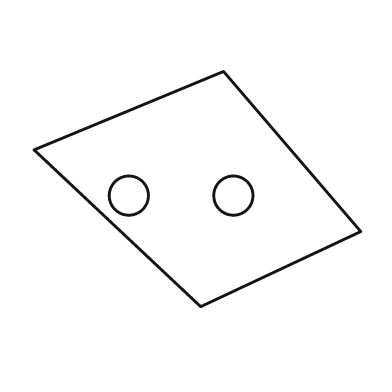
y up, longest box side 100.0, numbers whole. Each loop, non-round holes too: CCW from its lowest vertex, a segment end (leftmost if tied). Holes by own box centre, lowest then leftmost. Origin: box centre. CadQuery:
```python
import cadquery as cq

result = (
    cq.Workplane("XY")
    .moveTo(1.0, -36.0)
    .lineTo(50.0, -13.0)
    .lineTo(8.0, 36.0)
    .lineTo(-50.0, 12.0)
    .close()
    .moveTo(-21.0, -2.0)
    .circle(6.0)
    .moveTo(11.0, -2.0)
    .circle(6.0)
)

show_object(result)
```